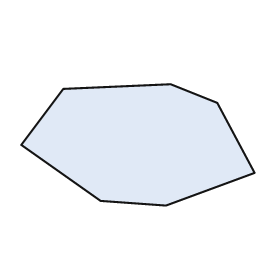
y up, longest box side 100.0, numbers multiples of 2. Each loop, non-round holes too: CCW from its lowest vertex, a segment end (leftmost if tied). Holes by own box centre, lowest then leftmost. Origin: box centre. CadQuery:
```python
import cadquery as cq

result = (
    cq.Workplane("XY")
    .moveTo(12.0, -26.0)
    .lineTo(50.0, -12.0)
    .lineTo(34.0, 18.0)
    .lineTo(14.0, 26.0)
    .lineTo(-32.0, 24.0)
    .lineTo(-50.0, 0.0)
    .lineTo(-16.0, -24.0)
    .close()
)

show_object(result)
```